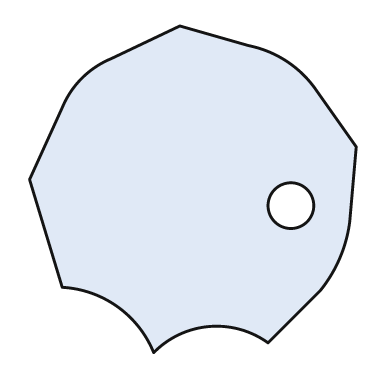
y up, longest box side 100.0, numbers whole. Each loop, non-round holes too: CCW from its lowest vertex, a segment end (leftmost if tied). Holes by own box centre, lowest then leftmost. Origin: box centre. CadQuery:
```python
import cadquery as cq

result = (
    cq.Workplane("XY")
    .moveTo(-12.0, -50.0)
    .threePointArc((5.0, -42.0), (23.0, -47.0))
    .lineTo(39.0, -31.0)
    .threePointArc((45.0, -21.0), (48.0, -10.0))
    .lineTo(50.0, 13.0)
    .lineTo(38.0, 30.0)
    .threePointArc((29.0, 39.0), (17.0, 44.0))
    .lineTo(-4.0, 50.0)
    .lineTo(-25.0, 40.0)
    .threePointArc((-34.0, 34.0), (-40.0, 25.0))
    .lineTo(-50.0, 3.0)
    .lineTo(-40.0, -30.0)
    .threePointArc((-23.0, -36.0), (-12.0, -50.0))
    .close()
    .moveTo(30.0, -5.0)
    .circle(7.0)
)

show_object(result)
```